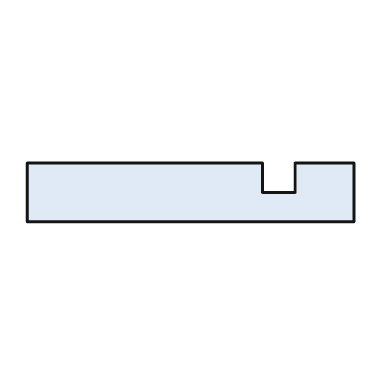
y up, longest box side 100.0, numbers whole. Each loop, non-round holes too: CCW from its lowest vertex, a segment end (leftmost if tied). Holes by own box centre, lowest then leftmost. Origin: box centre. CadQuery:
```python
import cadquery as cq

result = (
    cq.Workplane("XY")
    .moveTo(-50.0, -9.0)
    .lineTo(50.0, -9.0)
    .lineTo(50.0, 9.0)
    .lineTo(32.0, 9.0)
    .lineTo(32.0, 0.0)
    .lineTo(22.0, 0.0)
    .lineTo(22.0, 9.0)
    .lineTo(-50.0, 9.0)
    .close()
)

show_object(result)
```